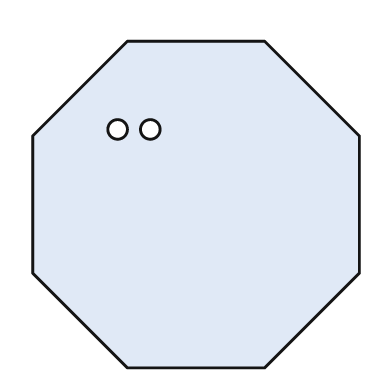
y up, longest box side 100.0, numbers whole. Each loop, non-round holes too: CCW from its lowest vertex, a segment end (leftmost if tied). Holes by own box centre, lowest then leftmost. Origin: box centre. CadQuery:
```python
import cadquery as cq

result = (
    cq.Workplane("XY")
    .moveTo(-21.0, -50.0)
    .lineTo(21.0, -50.0)
    .lineTo(50.0, -21.0)
    .lineTo(50.0, 21.0)
    .lineTo(21.0, 50.0)
    .lineTo(-21.0, 50.0)
    .lineTo(-50.0, 21.0)
    .lineTo(-50.0, -21.0)
    .close()
    .moveTo(-24.0, 23.0)
    .circle(3.0)
    .moveTo(-14.0, 23.0)
    .circle(3.0)
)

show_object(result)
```